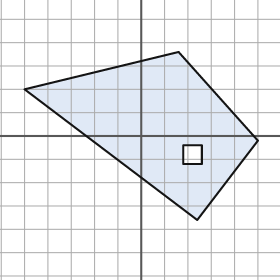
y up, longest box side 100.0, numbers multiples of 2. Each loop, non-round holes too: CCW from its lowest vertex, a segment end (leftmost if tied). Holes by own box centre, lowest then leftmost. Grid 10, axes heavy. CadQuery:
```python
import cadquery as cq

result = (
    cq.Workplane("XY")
    .moveTo(24.0, -36.0)
    .lineTo(50.0, -2.0)
    .lineTo(16.0, 36.0)
    .lineTo(-50.0, 20.0)
    .close()
    .moveTo(18.0, -12.0)
    .lineTo(26.0, -12.0)
    .lineTo(26.0, -4.0)
    .lineTo(18.0, -4.0)
    .close()
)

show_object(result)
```